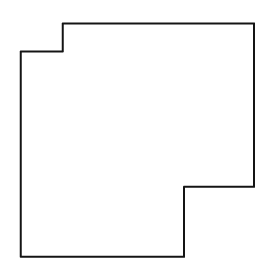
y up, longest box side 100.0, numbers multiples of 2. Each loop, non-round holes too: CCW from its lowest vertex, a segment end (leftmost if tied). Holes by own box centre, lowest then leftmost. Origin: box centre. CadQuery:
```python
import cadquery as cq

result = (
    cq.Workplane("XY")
    .moveTo(-50.0, -50.0)
    .lineTo(20.0, -50.0)
    .lineTo(20.0, -20.0)
    .lineTo(50.0, -20.0)
    .lineTo(50.0, 50.0)
    .lineTo(-32.0, 50.0)
    .lineTo(-32.0, 38.0)
    .lineTo(-50.0, 38.0)
    .close()
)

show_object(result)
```